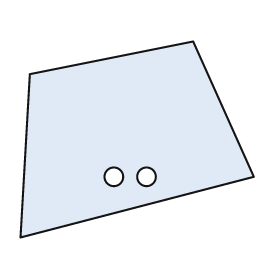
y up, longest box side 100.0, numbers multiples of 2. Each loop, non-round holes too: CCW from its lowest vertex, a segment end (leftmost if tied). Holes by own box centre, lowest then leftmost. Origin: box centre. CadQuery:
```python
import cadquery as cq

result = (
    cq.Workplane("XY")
    .moveTo(-50.0, -42.0)
    .lineTo(50.0, -16.0)
    .lineTo(24.0, 42.0)
    .lineTo(-46.0, 28.0)
    .close()
    .moveTo(-10.0, -16.0)
    .circle(4.0)
    .moveTo(4.0, -16.0)
    .circle(4.0)
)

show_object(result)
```